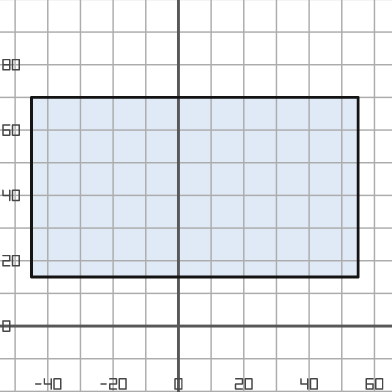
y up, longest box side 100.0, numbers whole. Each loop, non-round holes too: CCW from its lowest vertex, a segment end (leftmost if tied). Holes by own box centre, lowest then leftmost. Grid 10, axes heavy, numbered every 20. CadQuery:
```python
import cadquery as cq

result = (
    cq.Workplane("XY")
    .moveTo(-45.0, 15.0)
    .lineTo(55.0, 15.0)
    .lineTo(55.0, 70.0)
    .lineTo(-45.0, 70.0)
    .close()
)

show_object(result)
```